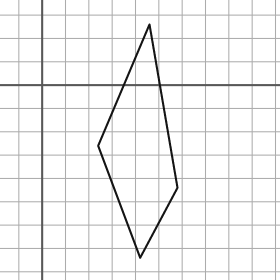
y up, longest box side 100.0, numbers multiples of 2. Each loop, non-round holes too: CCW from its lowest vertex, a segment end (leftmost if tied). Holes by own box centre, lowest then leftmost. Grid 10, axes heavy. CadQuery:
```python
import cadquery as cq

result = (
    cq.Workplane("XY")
    .moveTo(42.0, -74.0)
    .lineTo(58.0, -44.0)
    .lineTo(46.0, 26.0)
    .lineTo(24.0, -26.0)
    .close()
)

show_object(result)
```